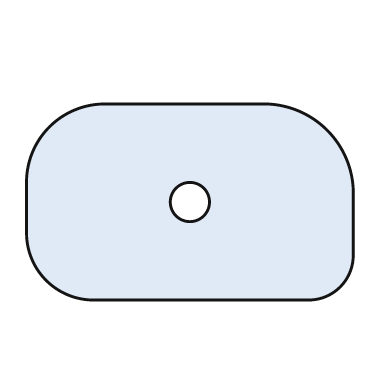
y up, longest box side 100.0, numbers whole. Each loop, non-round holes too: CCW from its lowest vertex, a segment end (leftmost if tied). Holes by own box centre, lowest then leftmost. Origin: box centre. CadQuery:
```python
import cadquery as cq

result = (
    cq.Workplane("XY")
    .moveTo(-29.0, -30.0)
    .lineTo(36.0, -30.0)
    .threePointArc((46.0, -26.0), (50.0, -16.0))
    .lineTo(50.0, 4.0)
    .threePointArc((42.0, 22.0), (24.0, 30.0))
    .lineTo(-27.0, 30.0)
    .threePointArc((-43.0, 23.0), (-50.0, 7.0))
    .lineTo(-50.0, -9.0)
    .threePointArc((-44.0, -24.0), (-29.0, -30.0))
    .close()
    .moveTo(0.0, 0.0)
    .circle(6.0)
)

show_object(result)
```